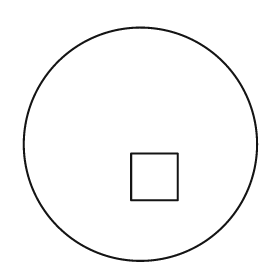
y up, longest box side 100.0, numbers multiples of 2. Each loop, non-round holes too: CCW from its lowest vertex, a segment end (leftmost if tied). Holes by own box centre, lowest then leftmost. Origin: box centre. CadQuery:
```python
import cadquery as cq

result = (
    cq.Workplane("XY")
    .moveTo(0.0, 0.0)
    .circle(50.0)
    .moveTo(-4.0, -24.0)
    .lineTo(16.0, -24.0)
    .lineTo(16.0, -4.0)
    .lineTo(-4.0, -4.0)
    .close()
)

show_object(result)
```